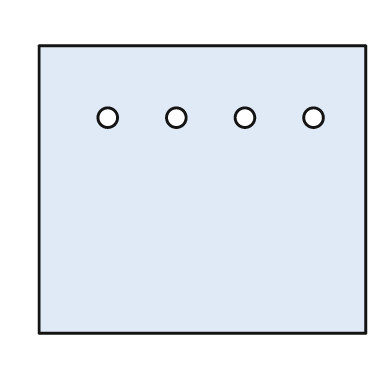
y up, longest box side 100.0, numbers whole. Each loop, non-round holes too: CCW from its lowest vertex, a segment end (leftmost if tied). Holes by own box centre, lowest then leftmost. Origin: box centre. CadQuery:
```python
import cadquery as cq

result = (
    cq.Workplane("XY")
    .moveTo(-50.0, -44.0)
    .lineTo(50.0, -44.0)
    .lineTo(50.0, 44.0)
    .lineTo(-50.0, 44.0)
    .close()
    .moveTo(-29.0, 22.0)
    .circle(3.0)
    .moveTo(-8.0, 22.0)
    .circle(3.0)
    .moveTo(13.0, 22.0)
    .circle(3.0)
    .moveTo(34.0, 22.0)
    .circle(3.0)
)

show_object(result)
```